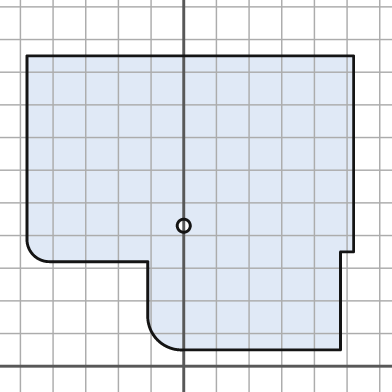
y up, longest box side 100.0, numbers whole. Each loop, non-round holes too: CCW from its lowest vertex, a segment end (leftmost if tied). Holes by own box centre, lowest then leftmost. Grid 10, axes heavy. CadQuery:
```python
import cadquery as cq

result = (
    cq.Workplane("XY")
    .moveTo(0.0, 5.0)
    .lineTo(48.0, 5.0)
    .lineTo(48.0, 35.0)
    .lineTo(52.0, 35.0)
    .lineTo(52.0, 95.0)
    .lineTo(-48.0, 95.0)
    .lineTo(-48.0, 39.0)
    .threePointArc((-46.0, 34.0), (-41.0, 32.0))
    .lineTo(-11.0, 32.0)
    .lineTo(-11.0, 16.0)
    .threePointArc((-8.0, 8.0), (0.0, 5.0))
    .close()
    .moveTo(0.0, 43.0)
    .circle(2.0)
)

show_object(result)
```